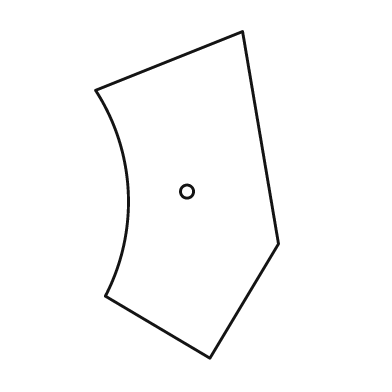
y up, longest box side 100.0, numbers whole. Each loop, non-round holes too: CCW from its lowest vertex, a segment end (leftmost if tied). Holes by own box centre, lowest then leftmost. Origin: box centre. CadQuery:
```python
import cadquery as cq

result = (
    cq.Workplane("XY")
    .moveTo(7.0, -50.0)
    .lineTo(28.0, -15.0)
    .lineTo(17.0, 50.0)
    .lineTo(-28.0, 32.0)
    .threePointArc((-18.0, 1.0), (-25.0, -31.0))
    .close()
    .moveTo(0.0, 1.0)
    .circle(2.0)
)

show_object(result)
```